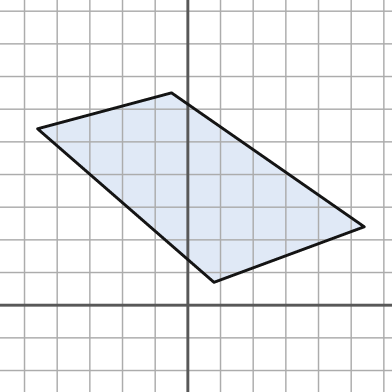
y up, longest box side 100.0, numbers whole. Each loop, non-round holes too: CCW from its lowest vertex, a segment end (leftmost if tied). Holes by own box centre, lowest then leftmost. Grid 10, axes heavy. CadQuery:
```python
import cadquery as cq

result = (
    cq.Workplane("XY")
    .moveTo(8.0, 7.0)
    .lineTo(54.0, 24.0)
    .lineTo(-5.0, 65.0)
    .lineTo(-46.0, 54.0)
    .close()
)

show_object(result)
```